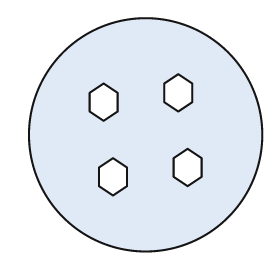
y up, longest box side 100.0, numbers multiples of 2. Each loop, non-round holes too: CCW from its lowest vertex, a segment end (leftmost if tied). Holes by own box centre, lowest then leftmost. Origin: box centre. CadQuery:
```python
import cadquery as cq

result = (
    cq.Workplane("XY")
    .moveTo(0.0, 0.0)
    .circle(50.0)
    .moveTo(-14.0, -26.0)
    .lineTo(-8.0, -22.0)
    .lineTo(-8.0, -14.0)
    .lineTo(-14.0, -10.0)
    .lineTo(-20.0, -14.0)
    .lineTo(-20.0, -22.0)
    .close()
    .moveTo(18.0, -22.0)
    .lineTo(24.0, -18.0)
    .lineTo(24.0, -10.0)
    .lineTo(18.0, -6.0)
    .lineTo(12.0, -10.0)
    .lineTo(12.0, -18.0)
    .close()
    .moveTo(-18.0, 6.0)
    .lineTo(-12.0, 10.0)
    .lineTo(-12.0, 18.0)
    .lineTo(-18.0, 22.0)
    .lineTo(-24.0, 18.0)
    .lineTo(-24.0, 10.0)
    .close()
    .moveTo(14.0, 10.0)
    .lineTo(20.0, 14.0)
    .lineTo(20.0, 22.0)
    .lineTo(14.0, 26.0)
    .lineTo(8.0, 22.0)
    .lineTo(8.0, 14.0)
    .close()
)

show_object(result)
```